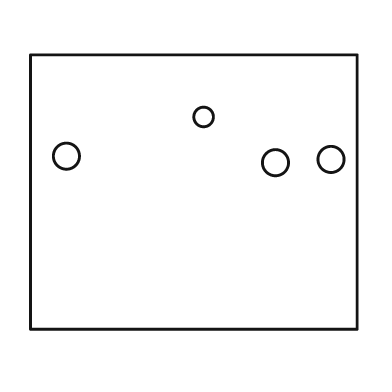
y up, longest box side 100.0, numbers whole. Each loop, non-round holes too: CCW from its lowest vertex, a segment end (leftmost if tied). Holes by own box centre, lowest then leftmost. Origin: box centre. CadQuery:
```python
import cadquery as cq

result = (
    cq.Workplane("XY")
    .moveTo(-50.0, -42.0)
    .lineTo(50.0, -42.0)
    .lineTo(50.0, 42.0)
    .lineTo(-50.0, 42.0)
    .close()
    .moveTo(25.0, 9.0)
    .circle(4.0)
    .moveTo(42.0, 10.0)
    .circle(4.0)
    .moveTo(-39.0, 11.0)
    .circle(4.0)
    .moveTo(3.0, 23.0)
    .circle(3.0)
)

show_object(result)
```